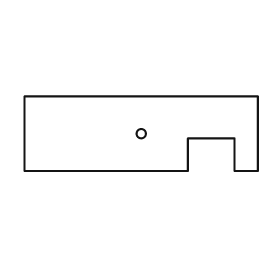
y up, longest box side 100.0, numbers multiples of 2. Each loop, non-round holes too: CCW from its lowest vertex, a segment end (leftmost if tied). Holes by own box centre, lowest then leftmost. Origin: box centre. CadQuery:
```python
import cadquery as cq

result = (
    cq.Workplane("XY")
    .moveTo(-50.0, -16.0)
    .lineTo(20.0, -16.0)
    .lineTo(20.0, -2.0)
    .lineTo(40.0, -2.0)
    .lineTo(40.0, -16.0)
    .lineTo(50.0, -16.0)
    .lineTo(50.0, 16.0)
    .lineTo(-50.0, 16.0)
    .close()
    .moveTo(0.0, 0.0)
    .circle(2.0)
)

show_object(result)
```